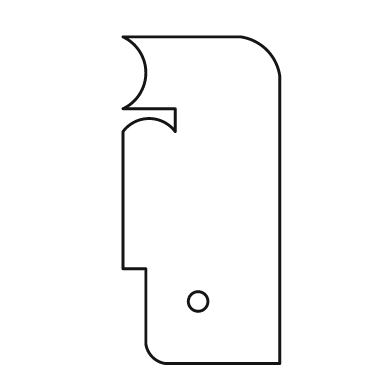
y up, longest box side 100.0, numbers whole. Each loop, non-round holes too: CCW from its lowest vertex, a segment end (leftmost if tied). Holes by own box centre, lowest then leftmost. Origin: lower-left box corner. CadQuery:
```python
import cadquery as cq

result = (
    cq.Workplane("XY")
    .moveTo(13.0, 0.0)
    .lineTo(48.0, 0.0)
    .lineTo(48.0, 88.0)
    .threePointArc((44.0, 96.0), (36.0, 100.0))
    .lineTo(0.0, 100.0)
    .threePointArc((7.0, 89.0), (0.0, 78.0))
    .lineTo(16.0, 78.0)
    .lineTo(16.0, 71.0)
    .threePointArc((8.0, 75.0), (0.0, 71.0))
    .lineTo(0.0, 29.0)
    .lineTo(7.0, 29.0)
    .lineTo(7.0, 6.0)
    .threePointArc((9.0, 2.0), (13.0, 0.0))
    .close()
    .moveTo(23.0, 19.0)
    .circle(3.0)
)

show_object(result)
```